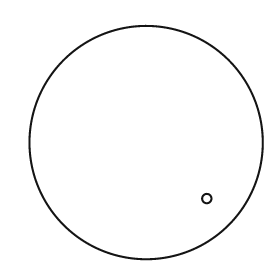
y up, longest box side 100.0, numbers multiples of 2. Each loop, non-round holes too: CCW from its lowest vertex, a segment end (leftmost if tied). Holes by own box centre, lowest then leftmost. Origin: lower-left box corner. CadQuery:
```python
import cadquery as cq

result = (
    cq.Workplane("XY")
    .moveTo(50.0, 50.0)
    .circle(50.0)
    .moveTo(76.0, 26.0)
    .circle(2.0)
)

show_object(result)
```